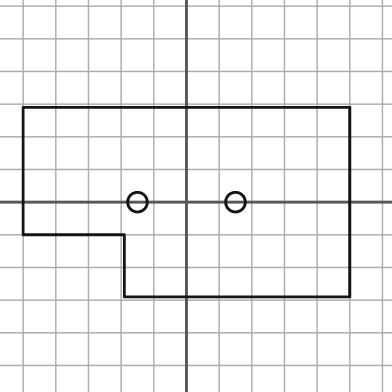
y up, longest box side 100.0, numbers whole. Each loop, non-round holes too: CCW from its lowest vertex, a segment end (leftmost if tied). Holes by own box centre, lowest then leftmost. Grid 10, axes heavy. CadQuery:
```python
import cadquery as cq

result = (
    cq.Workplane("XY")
    .moveTo(-19.0, -29.0)
    .lineTo(50.0, -29.0)
    .lineTo(50.0, 29.0)
    .lineTo(-50.0, 29.0)
    .lineTo(-50.0, -10.0)
    .lineTo(-19.0, -10.0)
    .close()
    .moveTo(-15.0, 0.0)
    .circle(3.0)
    .moveTo(15.0, 0.0)
    .circle(3.0)
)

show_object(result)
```